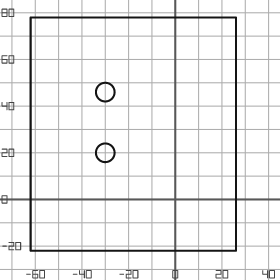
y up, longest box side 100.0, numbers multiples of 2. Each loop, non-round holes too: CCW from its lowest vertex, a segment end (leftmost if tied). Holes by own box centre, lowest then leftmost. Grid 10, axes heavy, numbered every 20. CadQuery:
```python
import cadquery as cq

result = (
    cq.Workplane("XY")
    .moveTo(-62.0, -22.0)
    .lineTo(26.0, -22.0)
    .lineTo(26.0, 78.0)
    .lineTo(-62.0, 78.0)
    .close()
    .moveTo(-30.0, 20.0)
    .circle(4.0)
    .moveTo(-30.0, 46.0)
    .circle(4.0)
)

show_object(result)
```